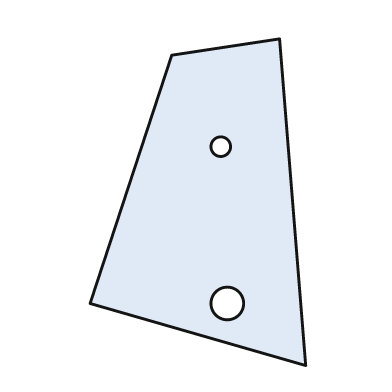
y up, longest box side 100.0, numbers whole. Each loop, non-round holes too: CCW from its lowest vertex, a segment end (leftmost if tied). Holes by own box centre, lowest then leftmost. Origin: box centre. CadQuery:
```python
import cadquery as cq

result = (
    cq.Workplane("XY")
    .moveTo(33.0, -50.0)
    .lineTo(25.0, 50.0)
    .lineTo(-8.0, 45.0)
    .lineTo(-33.0, -31.0)
    .close()
    .moveTo(9.0, -31.0)
    .circle(5.0)
    .moveTo(7.0, 17.0)
    .circle(3.0)
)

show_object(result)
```